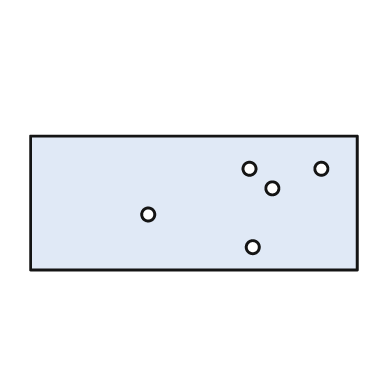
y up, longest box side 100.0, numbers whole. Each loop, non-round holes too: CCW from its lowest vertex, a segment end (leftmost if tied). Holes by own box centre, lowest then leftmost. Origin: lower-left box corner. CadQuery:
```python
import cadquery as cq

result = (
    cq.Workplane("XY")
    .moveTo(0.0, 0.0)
    .lineTo(100.0, 0.0)
    .lineTo(100.0, 41.0)
    .lineTo(0.0, 41.0)
    .close()
    .moveTo(68.0, 7.0)
    .circle(2.0)
    .moveTo(36.0, 17.0)
    .circle(2.0)
    .moveTo(74.0, 25.0)
    .circle(2.0)
    .moveTo(67.0, 31.0)
    .circle(2.0)
    .moveTo(89.0, 31.0)
    .circle(2.0)
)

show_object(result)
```